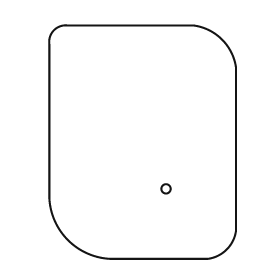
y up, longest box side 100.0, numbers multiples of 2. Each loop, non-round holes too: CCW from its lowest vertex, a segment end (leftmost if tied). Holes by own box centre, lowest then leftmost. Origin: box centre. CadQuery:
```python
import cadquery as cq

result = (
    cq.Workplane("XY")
    .moveTo(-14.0, -50.0)
    .lineTo(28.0, -50.0)
    .threePointArc((36.0, -46.0), (40.0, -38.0))
    .lineTo(40.0, 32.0)
    .threePointArc((34.0, 44.0), (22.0, 50.0))
    .lineTo(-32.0, 50.0)
    .threePointArc((-38.0, 48.0), (-40.0, 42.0))
    .lineTo(-40.0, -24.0)
    .threePointArc((-32.0, -42.0), (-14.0, -50.0))
    .close()
    .moveTo(10.0, -20.0)
    .circle(2.0)
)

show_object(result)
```